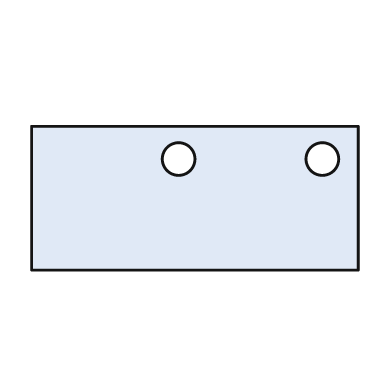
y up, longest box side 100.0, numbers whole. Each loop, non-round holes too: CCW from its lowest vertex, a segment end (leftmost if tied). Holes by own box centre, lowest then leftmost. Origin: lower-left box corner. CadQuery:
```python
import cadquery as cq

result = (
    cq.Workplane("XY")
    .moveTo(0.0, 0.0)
    .lineTo(100.0, 0.0)
    .lineTo(100.0, 44.0)
    .lineTo(0.0, 44.0)
    .close()
    .moveTo(45.0, 34.0)
    .circle(5.0)
    .moveTo(89.0, 34.0)
    .circle(5.0)
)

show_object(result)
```